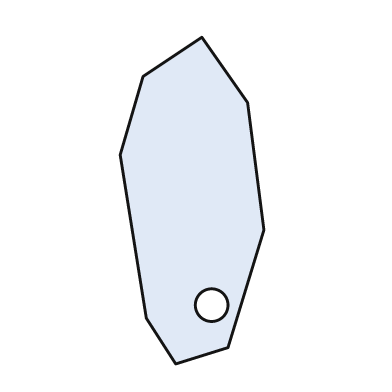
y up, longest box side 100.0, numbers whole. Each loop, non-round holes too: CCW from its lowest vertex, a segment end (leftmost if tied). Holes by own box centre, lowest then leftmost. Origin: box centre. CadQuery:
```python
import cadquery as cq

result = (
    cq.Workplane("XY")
    .moveTo(-5.0, -50.0)
    .lineTo(11.0, -45.0)
    .lineTo(22.0, -9.0)
    .lineTo(17.0, 30.0)
    .lineTo(3.0, 50.0)
    .lineTo(-15.0, 38.0)
    .lineTo(-22.0, 14.0)
    .lineTo(-14.0, -36.0)
    .close()
    .moveTo(6.0, -32.0)
    .circle(5.0)
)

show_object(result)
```